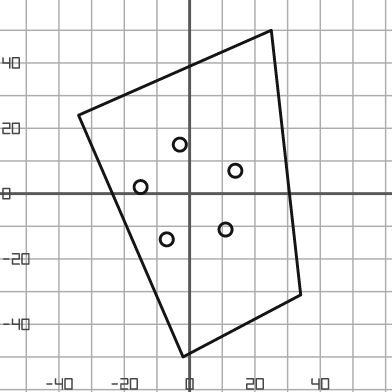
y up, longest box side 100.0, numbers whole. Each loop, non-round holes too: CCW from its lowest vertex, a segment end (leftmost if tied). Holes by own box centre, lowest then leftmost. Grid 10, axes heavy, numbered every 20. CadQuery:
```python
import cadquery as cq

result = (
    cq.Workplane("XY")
    .moveTo(-2.0, -50.0)
    .lineTo(34.0, -31.0)
    .lineTo(25.0, 50.0)
    .lineTo(-34.0, 24.0)
    .close()
    .moveTo(-7.0, -14.0)
    .circle(2.0)
    .moveTo(11.0, -11.0)
    .circle(2.0)
    .moveTo(-15.0, 2.0)
    .circle(2.0)
    .moveTo(14.0, 7.0)
    .circle(2.0)
    .moveTo(-3.0, 15.0)
    .circle(2.0)
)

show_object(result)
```